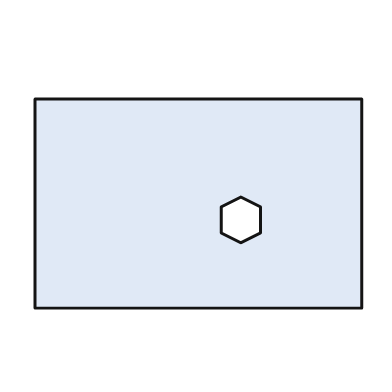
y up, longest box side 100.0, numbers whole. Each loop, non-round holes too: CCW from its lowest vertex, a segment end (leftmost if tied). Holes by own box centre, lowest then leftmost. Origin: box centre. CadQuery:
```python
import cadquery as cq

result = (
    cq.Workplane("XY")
    .moveTo(-50.0, -32.0)
    .lineTo(50.0, -32.0)
    .lineTo(50.0, 32.0)
    .lineTo(-50.0, 32.0)
    .close()
    .moveTo(13.0, -12.0)
    .lineTo(19.0, -9.0)
    .lineTo(19.0, -1.0)
    .lineTo(13.0, 2.0)
    .lineTo(7.0, -1.0)
    .lineTo(7.0, -9.0)
    .close()
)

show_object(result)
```